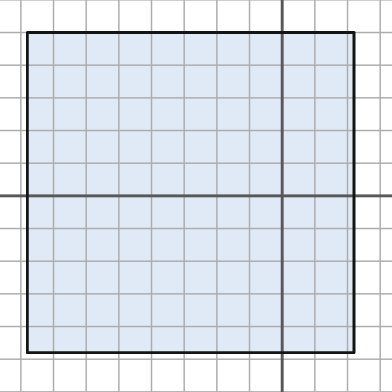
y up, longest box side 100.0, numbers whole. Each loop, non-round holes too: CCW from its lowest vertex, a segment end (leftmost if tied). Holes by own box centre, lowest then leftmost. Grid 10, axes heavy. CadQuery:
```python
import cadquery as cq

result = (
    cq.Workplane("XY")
    .moveTo(-78.0, -48.0)
    .lineTo(22.0, -48.0)
    .lineTo(22.0, 50.0)
    .lineTo(-78.0, 50.0)
    .close()
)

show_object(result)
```